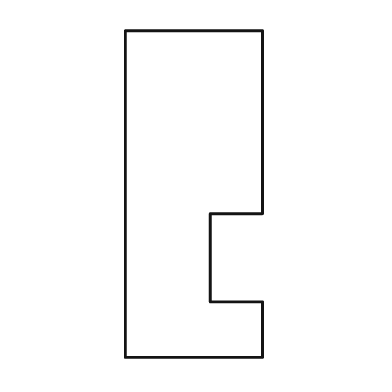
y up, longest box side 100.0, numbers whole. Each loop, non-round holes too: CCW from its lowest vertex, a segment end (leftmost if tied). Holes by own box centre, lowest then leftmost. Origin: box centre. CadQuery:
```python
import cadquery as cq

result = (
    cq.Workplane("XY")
    .moveTo(-21.0, -50.0)
    .lineTo(21.0, -50.0)
    .lineTo(21.0, -33.0)
    .lineTo(5.0, -33.0)
    .lineTo(5.0, -6.0)
    .lineTo(21.0, -6.0)
    .lineTo(21.0, 50.0)
    .lineTo(-21.0, 50.0)
    .close()
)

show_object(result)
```